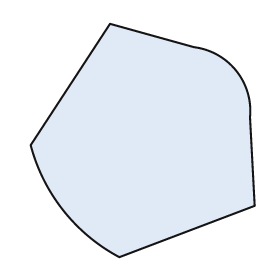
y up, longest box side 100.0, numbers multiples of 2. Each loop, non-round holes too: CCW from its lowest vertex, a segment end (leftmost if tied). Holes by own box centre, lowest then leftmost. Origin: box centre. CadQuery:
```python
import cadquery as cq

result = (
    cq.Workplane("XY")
    .moveTo(-10.0, -50.0)
    .lineTo(48.0, -28.0)
    .lineTo(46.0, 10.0)
    .threePointArc((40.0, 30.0), (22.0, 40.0))
    .lineTo(-14.0, 50.0)
    .lineTo(-48.0, -2.0)
    .threePointArc((-34.0, -30.0), (-10.0, -50.0))
    .close()
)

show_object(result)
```